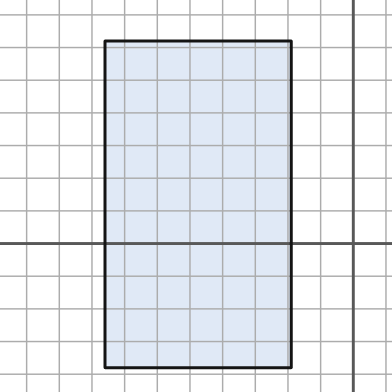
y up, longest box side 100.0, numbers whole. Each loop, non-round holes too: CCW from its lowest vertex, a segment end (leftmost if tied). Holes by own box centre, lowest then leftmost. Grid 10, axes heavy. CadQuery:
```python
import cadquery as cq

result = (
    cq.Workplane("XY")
    .moveTo(-76.0, -38.0)
    .lineTo(-19.0, -38.0)
    .lineTo(-19.0, 62.0)
    .lineTo(-76.0, 62.0)
    .close()
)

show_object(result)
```